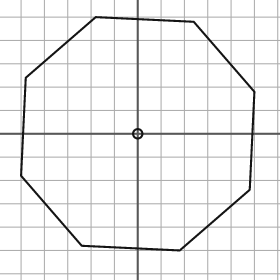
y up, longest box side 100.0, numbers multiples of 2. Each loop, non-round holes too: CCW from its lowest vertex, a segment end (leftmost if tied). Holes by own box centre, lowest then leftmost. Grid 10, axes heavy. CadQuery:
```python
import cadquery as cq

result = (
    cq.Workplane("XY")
    .moveTo(18.0, -50.0)
    .lineTo(48.0, -24.0)
    .lineTo(50.0, 18.0)
    .lineTo(24.0, 48.0)
    .lineTo(-18.0, 50.0)
    .lineTo(-48.0, 24.0)
    .lineTo(-50.0, -18.0)
    .lineTo(-24.0, -48.0)
    .close()
    .moveTo(0.0, 0.0)
    .circle(2.0)
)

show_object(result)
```